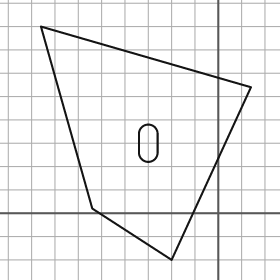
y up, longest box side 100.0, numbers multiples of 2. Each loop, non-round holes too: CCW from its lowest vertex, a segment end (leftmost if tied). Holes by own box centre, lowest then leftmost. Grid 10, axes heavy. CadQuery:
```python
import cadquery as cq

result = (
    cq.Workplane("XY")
    .moveTo(-20.0, -20.0)
    .lineTo(14.0, 54.0)
    .lineTo(-76.0, 80.0)
    .lineTo(-54.0, 2.0)
    .close()
    .moveTo(-34.0, 26.0)
    .threePointArc((-30.0, 22.0), (-26.0, 26.0))
    .lineTo(-26.0, 34.0)
    .threePointArc((-30.0, 38.0), (-34.0, 34.0))
    .close()
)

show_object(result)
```